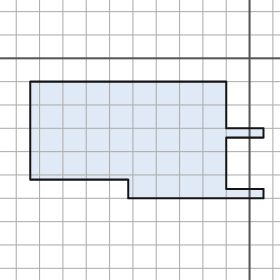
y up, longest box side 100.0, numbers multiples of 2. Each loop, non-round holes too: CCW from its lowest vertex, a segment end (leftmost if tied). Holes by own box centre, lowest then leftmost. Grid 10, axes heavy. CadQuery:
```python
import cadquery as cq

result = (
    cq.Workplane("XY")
    .moveTo(-52.0, -60.0)
    .lineTo(6.0, -60.0)
    .lineTo(6.0, -56.0)
    .lineTo(-10.0, -56.0)
    .lineTo(-10.0, -34.0)
    .lineTo(6.0, -34.0)
    .lineTo(6.0, -30.0)
    .lineTo(-10.0, -30.0)
    .lineTo(-10.0, -10.0)
    .lineTo(-94.0, -10.0)
    .lineTo(-94.0, -52.0)
    .lineTo(-52.0, -52.0)
    .close()
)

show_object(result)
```